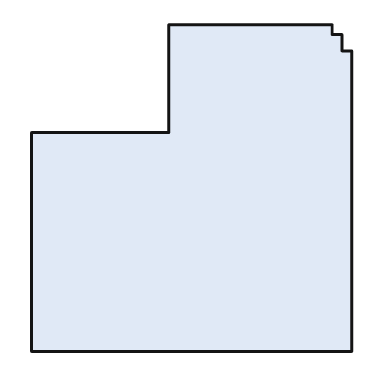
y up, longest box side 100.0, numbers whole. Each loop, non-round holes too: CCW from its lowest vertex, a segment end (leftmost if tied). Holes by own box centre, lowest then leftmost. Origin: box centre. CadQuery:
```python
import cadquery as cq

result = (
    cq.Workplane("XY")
    .moveTo(-49.0, -50.0)
    .lineTo(49.0, -50.0)
    .lineTo(49.0, 42.0)
    .lineTo(46.0, 42.0)
    .lineTo(46.0, 47.0)
    .lineTo(43.0, 47.0)
    .lineTo(43.0, 50.0)
    .lineTo(-7.0, 50.0)
    .lineTo(-7.0, 17.0)
    .lineTo(-49.0, 17.0)
    .close()
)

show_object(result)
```